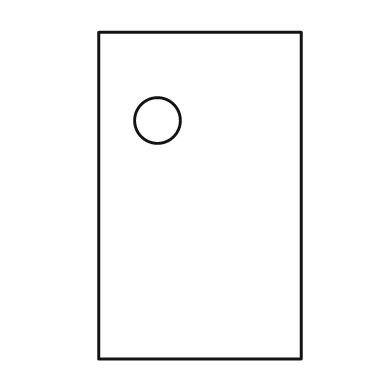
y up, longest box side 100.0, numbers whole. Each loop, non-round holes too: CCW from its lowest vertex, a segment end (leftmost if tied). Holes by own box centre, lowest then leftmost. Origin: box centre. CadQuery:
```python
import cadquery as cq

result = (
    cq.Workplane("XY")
    .moveTo(-31.0, -50.0)
    .lineTo(31.0, -50.0)
    .lineTo(31.0, 50.0)
    .lineTo(-31.0, 50.0)
    .close()
    .moveTo(-13.0, 23.0)
    .circle(7.0)
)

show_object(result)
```